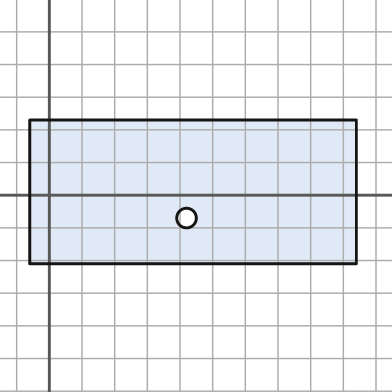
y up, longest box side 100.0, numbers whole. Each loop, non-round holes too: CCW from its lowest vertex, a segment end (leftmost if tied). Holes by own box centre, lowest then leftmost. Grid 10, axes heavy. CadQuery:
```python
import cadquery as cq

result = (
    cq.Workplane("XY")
    .moveTo(-6.0, -21.0)
    .lineTo(94.0, -21.0)
    .lineTo(94.0, 23.0)
    .lineTo(-6.0, 23.0)
    .close()
    .moveTo(42.0, -7.0)
    .circle(3.0)
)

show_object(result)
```